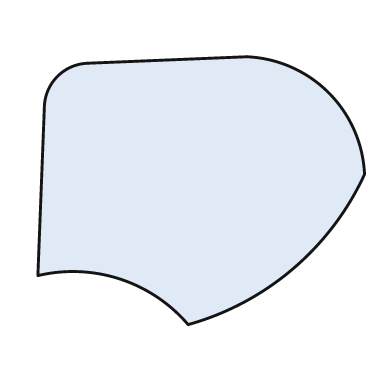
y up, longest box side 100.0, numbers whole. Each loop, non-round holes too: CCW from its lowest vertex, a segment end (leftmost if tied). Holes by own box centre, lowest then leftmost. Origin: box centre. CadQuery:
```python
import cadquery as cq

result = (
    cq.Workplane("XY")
    .moveTo(-4.0, -41.0)
    .threePointArc((28.0, -24.0), (50.0, 5.0))
    .threePointArc((39.0, 30.0), (14.0, 41.0))
    .lineTo(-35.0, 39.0)
    .threePointArc((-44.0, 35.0), (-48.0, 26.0))
    .lineTo(-50.0, -26.0)
    .threePointArc((-25.0, -27.0), (-4.0, -41.0))
    .close()
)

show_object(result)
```